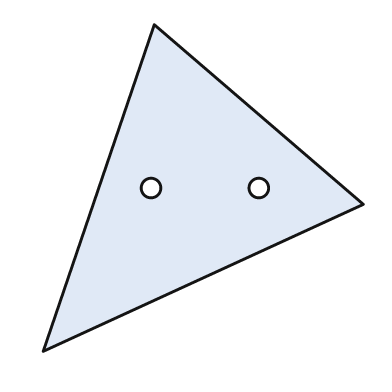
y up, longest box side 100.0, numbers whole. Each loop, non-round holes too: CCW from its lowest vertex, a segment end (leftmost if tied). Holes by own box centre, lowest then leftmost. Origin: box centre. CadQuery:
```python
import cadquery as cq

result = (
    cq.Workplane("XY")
    .moveTo(-49.0, -50.0)
    .lineTo(49.0, -5.0)
    .lineTo(-15.0, 50.0)
    .close()
    .moveTo(-16.0, 0.0)
    .circle(3.0)
    .moveTo(17.0, 0.0)
    .circle(3.0)
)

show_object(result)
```